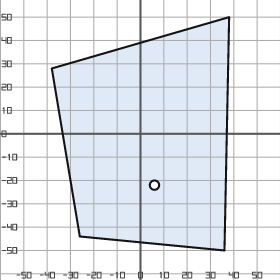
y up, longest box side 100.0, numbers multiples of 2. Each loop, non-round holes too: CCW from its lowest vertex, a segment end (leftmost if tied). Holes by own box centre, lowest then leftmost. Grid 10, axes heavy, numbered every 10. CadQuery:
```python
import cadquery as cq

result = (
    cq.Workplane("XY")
    .moveTo(36.0, -50.0)
    .lineTo(38.0, 50.0)
    .lineTo(-38.0, 28.0)
    .lineTo(-26.0, -44.0)
    .close()
    .moveTo(6.0, -22.0)
    .circle(2.0)
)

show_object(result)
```